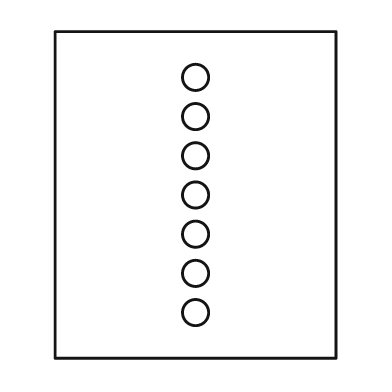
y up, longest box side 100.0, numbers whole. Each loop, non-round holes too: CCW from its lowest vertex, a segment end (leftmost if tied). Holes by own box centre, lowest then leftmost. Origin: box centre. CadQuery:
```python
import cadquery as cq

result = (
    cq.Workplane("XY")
    .moveTo(-43.0, -50.0)
    .lineTo(43.0, -50.0)
    .lineTo(43.0, 50.0)
    .lineTo(-43.0, 50.0)
    .close()
    .moveTo(0.0, -36.0)
    .circle(4.0)
    .moveTo(0.0, -24.0)
    .circle(4.0)
    .moveTo(0.0, -12.0)
    .circle(4.0)
    .moveTo(0.0, 0.0)
    .circle(4.0)
    .moveTo(0.0, 12.0)
    .circle(4.0)
    .moveTo(0.0, 24.0)
    .circle(4.0)
    .moveTo(0.0, 36.0)
    .circle(4.0)
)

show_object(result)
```